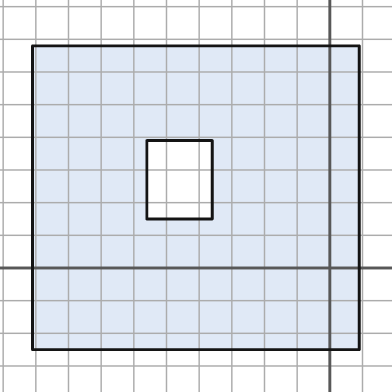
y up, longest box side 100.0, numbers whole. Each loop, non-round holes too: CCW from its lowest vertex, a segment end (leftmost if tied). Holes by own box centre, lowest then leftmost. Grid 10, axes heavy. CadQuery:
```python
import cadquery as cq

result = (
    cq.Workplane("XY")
    .moveTo(-91.0, -25.0)
    .lineTo(9.0, -25.0)
    .lineTo(9.0, 68.0)
    .lineTo(-91.0, 68.0)
    .close()
    .moveTo(-56.0, 15.0)
    .lineTo(-36.0, 15.0)
    .lineTo(-36.0, 39.0)
    .lineTo(-56.0, 39.0)
    .close()
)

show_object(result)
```